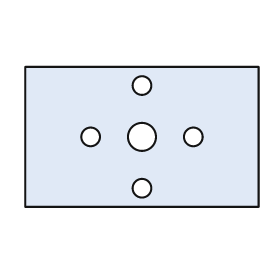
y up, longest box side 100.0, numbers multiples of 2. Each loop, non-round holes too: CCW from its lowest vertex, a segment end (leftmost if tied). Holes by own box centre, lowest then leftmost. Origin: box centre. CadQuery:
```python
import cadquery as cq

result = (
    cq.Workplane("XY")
    .moveTo(-50.0, -30.0)
    .lineTo(50.0, -30.0)
    .lineTo(50.0, 30.0)
    .lineTo(-50.0, 30.0)
    .close()
    .moveTo(0.0, -22.0)
    .circle(4.0)
    .moveTo(-22.0, 0.0)
    .circle(4.0)
    .moveTo(0.0, 0.0)
    .circle(6.0)
    .moveTo(22.0, 0.0)
    .circle(4.0)
    .moveTo(0.0, 22.0)
    .circle(4.0)
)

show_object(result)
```